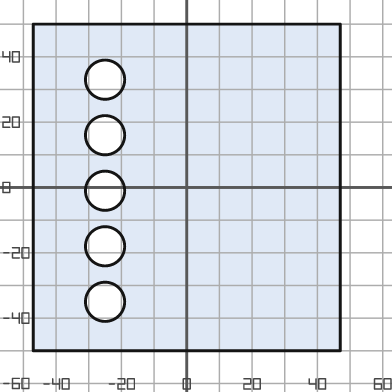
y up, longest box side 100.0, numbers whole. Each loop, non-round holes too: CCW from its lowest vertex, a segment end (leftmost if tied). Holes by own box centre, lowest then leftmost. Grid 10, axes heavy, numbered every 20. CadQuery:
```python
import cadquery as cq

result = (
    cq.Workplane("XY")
    .moveTo(-47.0, -50.0)
    .lineTo(47.0, -50.0)
    .lineTo(47.0, 50.0)
    .lineTo(-47.0, 50.0)
    .close()
    .moveTo(-25.0, -35.0)
    .circle(6.0)
    .moveTo(-25.0, -18.0)
    .circle(6.0)
    .moveTo(-25.0, -1.0)
    .circle(6.0)
    .moveTo(-25.0, 16.0)
    .circle(6.0)
    .moveTo(-25.0, 33.0)
    .circle(6.0)
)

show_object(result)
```